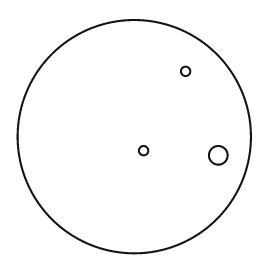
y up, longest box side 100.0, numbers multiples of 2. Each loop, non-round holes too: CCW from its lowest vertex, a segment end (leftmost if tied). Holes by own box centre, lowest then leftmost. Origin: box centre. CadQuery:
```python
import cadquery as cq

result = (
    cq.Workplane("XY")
    .moveTo(0.0, 0.0)
    .circle(50.0)
    .moveTo(36.0, -8.0)
    .circle(4.0)
    .moveTo(4.0, -6.0)
    .circle(2.0)
    .moveTo(22.0, 28.0)
    .circle(2.0)
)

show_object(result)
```